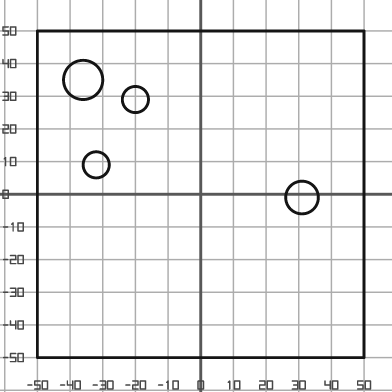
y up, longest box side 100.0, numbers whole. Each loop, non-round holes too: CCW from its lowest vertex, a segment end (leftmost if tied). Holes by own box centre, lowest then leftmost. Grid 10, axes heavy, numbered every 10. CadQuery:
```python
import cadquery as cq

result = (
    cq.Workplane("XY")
    .moveTo(-50.0, -50.0)
    .lineTo(50.0, -50.0)
    .lineTo(50.0, 50.0)
    .lineTo(-50.0, 50.0)
    .close()
    .moveTo(31.0, -1.0)
    .circle(5.0)
    .moveTo(-32.0, 9.0)
    .circle(4.0)
    .moveTo(-20.0, 29.0)
    .circle(4.0)
    .moveTo(-36.0, 35.0)
    .circle(6.0)
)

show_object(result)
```